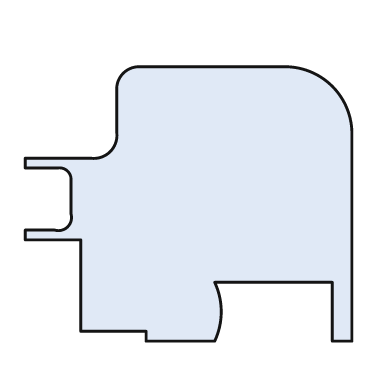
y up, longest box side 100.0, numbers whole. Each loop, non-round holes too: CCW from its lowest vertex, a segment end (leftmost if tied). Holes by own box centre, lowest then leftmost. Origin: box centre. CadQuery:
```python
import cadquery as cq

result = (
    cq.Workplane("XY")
    .moveTo(-13.0, -42.0)
    .lineTo(8.0, -42.0)
    .threePointArc((10.0, -33.0), (8.0, -24.0))
    .lineTo(44.0, -24.0)
    .lineTo(44.0, -42.0)
    .lineTo(50.0, -42.0)
    .lineTo(50.0, 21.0)
    .threePointArc((44.0, 36.0), (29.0, 42.0))
    .lineTo(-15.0, 42.0)
    .threePointArc((-20.0, 40.0), (-22.0, 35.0))
    .lineTo(-22.0, 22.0)
    .threePointArc((-24.0, 16.0), (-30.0, 14.0))
    .lineTo(-50.0, 14.0)
    .lineTo(-50.0, 11.0)
    .lineTo(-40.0, 11.0)
    .threePointArc((-37.0, 10.0), (-36.0, 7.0))
    .lineTo(-36.0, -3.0)
    .threePointArc((-37.0, -7.0), (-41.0, -8.0))
    .lineTo(-50.0, -8.0)
    .lineTo(-50.0, -11.0)
    .lineTo(-33.0, -11.0)
    .lineTo(-33.0, -39.0)
    .lineTo(-13.0, -39.0)
    .close()
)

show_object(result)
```